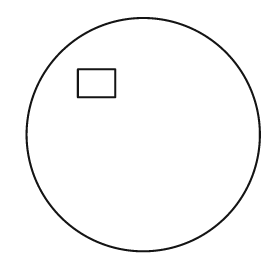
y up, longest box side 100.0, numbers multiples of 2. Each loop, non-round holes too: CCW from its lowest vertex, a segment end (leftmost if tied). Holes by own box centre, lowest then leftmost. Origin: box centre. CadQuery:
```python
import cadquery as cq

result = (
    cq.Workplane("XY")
    .moveTo(0.0, 0.0)
    .circle(50.0)
    .moveTo(-28.0, 16.0)
    .lineTo(-12.0, 16.0)
    .lineTo(-12.0, 28.0)
    .lineTo(-28.0, 28.0)
    .close()
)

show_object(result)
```